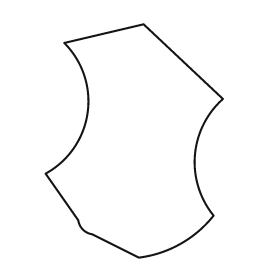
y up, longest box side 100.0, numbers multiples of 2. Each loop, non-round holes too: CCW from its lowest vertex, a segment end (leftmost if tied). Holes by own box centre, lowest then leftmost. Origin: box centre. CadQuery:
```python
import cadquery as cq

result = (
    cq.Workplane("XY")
    .moveTo(2.0, -50.0)
    .threePointArc((20.0, -44.0), (34.0, -32.0))
    .threePointArc((26.0, -6.0), (38.0, 18.0))
    .lineTo(4.0, 50.0)
    .lineTo(-30.0, 42.0)
    .threePointArc((-20.0, 12.0), (-38.0, -14.0))
    .lineTo(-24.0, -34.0)
    .threePointArc((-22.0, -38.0), (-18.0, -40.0))
    .close()
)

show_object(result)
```